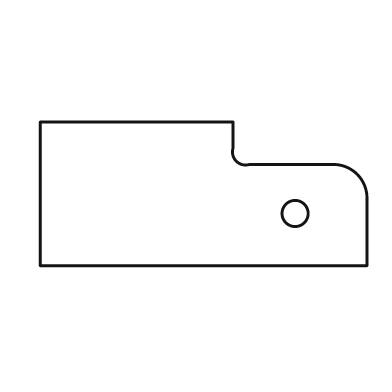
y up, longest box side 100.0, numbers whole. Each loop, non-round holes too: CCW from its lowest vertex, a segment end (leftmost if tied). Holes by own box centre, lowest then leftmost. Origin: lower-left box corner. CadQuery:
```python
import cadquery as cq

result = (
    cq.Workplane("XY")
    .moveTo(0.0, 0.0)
    .lineTo(100.0, 0.0)
    .lineTo(100.0, 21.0)
    .threePointArc((97.0, 28.0), (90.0, 31.0))
    .lineTo(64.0, 31.0)
    .threePointArc((60.0, 32.0), (59.0, 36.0))
    .lineTo(59.0, 44.0)
    .lineTo(0.0, 44.0)
    .close()
    .moveTo(78.0, 16.0)
    .circle(4.0)
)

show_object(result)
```